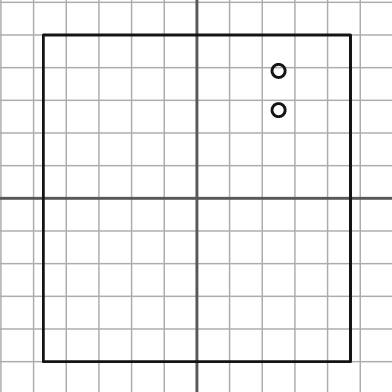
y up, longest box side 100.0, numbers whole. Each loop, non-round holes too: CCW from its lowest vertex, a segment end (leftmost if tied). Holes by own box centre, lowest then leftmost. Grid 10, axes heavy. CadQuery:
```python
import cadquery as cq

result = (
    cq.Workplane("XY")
    .moveTo(-47.0, -50.0)
    .lineTo(47.0, -50.0)
    .lineTo(47.0, 50.0)
    .lineTo(-47.0, 50.0)
    .close()
    .moveTo(25.0, 27.0)
    .circle(2.0)
    .moveTo(25.0, 39.0)
    .circle(2.0)
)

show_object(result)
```